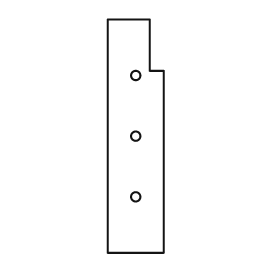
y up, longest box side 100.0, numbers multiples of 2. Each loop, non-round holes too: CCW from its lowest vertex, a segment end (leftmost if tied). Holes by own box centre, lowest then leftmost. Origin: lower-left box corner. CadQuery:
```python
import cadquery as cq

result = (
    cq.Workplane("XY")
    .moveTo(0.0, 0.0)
    .lineTo(24.0, 0.0)
    .lineTo(24.0, 78.0)
    .lineTo(18.0, 78.0)
    .lineTo(18.0, 100.0)
    .lineTo(0.0, 100.0)
    .close()
    .moveTo(12.0, 24.0)
    .circle(2.0)
    .moveTo(12.0, 50.0)
    .circle(2.0)
    .moveTo(12.0, 76.0)
    .circle(2.0)
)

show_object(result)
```